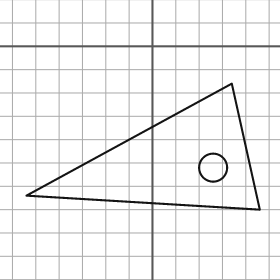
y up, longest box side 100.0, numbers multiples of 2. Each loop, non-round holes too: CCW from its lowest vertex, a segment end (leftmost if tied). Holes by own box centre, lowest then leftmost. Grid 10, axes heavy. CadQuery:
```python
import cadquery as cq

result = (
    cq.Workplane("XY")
    .moveTo(46.0, -70.0)
    .lineTo(34.0, -16.0)
    .lineTo(-54.0, -64.0)
    .close()
    .moveTo(26.0, -52.0)
    .circle(6.0)
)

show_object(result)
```